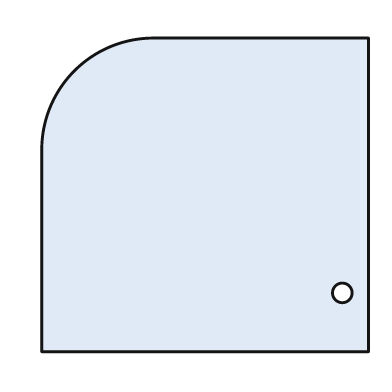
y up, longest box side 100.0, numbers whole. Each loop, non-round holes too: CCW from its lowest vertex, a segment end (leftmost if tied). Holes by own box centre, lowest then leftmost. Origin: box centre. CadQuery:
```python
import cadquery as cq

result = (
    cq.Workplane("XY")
    .moveTo(-50.0, -48.0)
    .lineTo(50.0, -48.0)
    .lineTo(50.0, 48.0)
    .lineTo(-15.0, 48.0)
    .threePointArc((-40.0, 38.0), (-50.0, 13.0))
    .close()
    .moveTo(42.0, -30.0)
    .circle(3.0)
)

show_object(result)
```